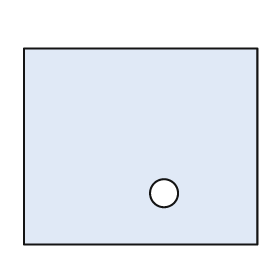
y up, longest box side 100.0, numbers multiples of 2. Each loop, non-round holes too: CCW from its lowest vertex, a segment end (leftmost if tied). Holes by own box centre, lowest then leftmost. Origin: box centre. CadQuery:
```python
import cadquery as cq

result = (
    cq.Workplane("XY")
    .moveTo(-50.0, -42.0)
    .lineTo(50.0, -42.0)
    .lineTo(50.0, 42.0)
    .lineTo(-50.0, 42.0)
    .close()
    .moveTo(10.0, -20.0)
    .circle(6.0)
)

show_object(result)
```